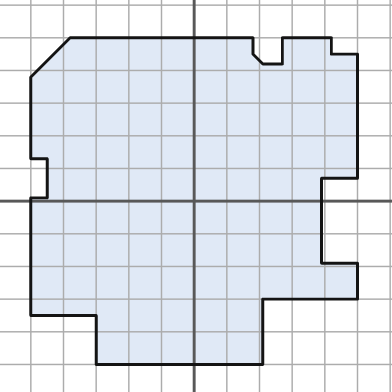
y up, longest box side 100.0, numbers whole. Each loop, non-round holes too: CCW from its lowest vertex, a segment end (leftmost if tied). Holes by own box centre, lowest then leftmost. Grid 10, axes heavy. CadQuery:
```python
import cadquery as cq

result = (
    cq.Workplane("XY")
    .moveTo(-30.0, -50.0)
    .lineTo(21.0, -50.0)
    .lineTo(21.0, -30.0)
    .lineTo(50.0, -30.0)
    .lineTo(50.0, -19.0)
    .lineTo(39.0, -19.0)
    .lineTo(39.0, 7.0)
    .lineTo(50.0, 7.0)
    .lineTo(50.0, 45.0)
    .lineTo(42.0, 45.0)
    .lineTo(42.0, 50.0)
    .lineTo(27.0, 50.0)
    .lineTo(27.0, 42.0)
    .lineTo(21.0, 42.0)
    .lineTo(18.0, 45.0)
    .lineTo(18.0, 50.0)
    .lineTo(-38.0, 50.0)
    .lineTo(-50.0, 38.0)
    .lineTo(-50.0, 13.0)
    .lineTo(-45.0, 13.0)
    .lineTo(-45.0, 1.0)
    .lineTo(-50.0, 1.0)
    .lineTo(-50.0, -35.0)
    .lineTo(-30.0, -35.0)
    .close()
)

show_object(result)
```